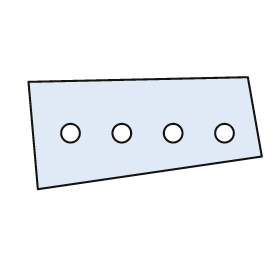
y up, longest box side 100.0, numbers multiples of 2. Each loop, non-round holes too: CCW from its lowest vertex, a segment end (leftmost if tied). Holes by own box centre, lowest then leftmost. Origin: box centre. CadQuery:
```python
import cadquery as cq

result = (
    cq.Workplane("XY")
    .moveTo(-46.0, -24.0)
    .lineTo(50.0, -10.0)
    .lineTo(44.0, 24.0)
    .lineTo(-50.0, 22.0)
    .close()
    .moveTo(-32.0, 0.0)
    .circle(4.0)
    .moveTo(-10.0, 0.0)
    .circle(4.0)
    .moveTo(12.0, 0.0)
    .circle(4.0)
    .moveTo(34.0, 0.0)
    .circle(4.0)
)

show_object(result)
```